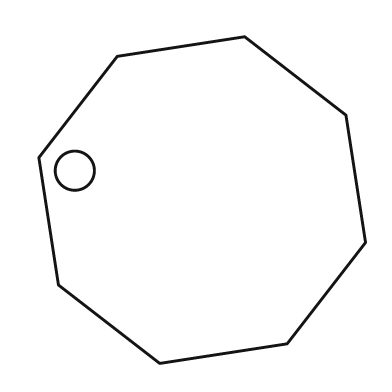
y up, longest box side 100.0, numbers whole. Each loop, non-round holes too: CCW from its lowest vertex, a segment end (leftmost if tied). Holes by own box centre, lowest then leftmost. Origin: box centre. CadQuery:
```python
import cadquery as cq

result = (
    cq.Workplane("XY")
    .moveTo(-13.0, -50.0)
    .lineTo(26.0, -44.0)
    .lineTo(50.0, -13.0)
    .lineTo(44.0, 26.0)
    .lineTo(13.0, 50.0)
    .lineTo(-26.0, 44.0)
    .lineTo(-50.0, 13.0)
    .lineTo(-44.0, -26.0)
    .close()
    .moveTo(-39.0, 9.0)
    .circle(6.0)
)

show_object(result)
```